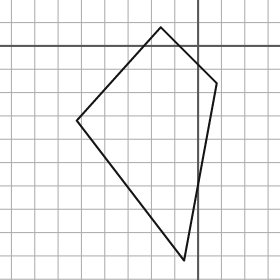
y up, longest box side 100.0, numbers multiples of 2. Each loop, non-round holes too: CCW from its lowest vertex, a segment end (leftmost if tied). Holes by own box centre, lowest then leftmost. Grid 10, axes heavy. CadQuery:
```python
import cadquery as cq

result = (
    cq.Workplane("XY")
    .moveTo(-6.0, -92.0)
    .lineTo(8.0, -16.0)
    .lineTo(-16.0, 8.0)
    .lineTo(-52.0, -32.0)
    .close()
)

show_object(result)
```